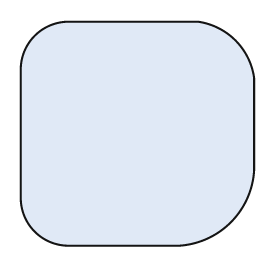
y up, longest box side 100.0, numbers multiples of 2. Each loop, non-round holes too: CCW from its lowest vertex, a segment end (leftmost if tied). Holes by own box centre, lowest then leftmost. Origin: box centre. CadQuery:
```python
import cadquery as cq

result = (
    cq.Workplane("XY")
    .moveTo(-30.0, -48.0)
    .lineTo(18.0, -48.0)
    .threePointArc((40.0, -38.0), (50.0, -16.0))
    .lineTo(50.0, 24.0)
    .threePointArc((42.0, 40.0), (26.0, 48.0))
    .lineTo(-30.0, 48.0)
    .threePointArc((-44.0, 42.0), (-50.0, 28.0))
    .lineTo(-50.0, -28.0)
    .threePointArc((-44.0, -42.0), (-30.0, -48.0))
    .close()
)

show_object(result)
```